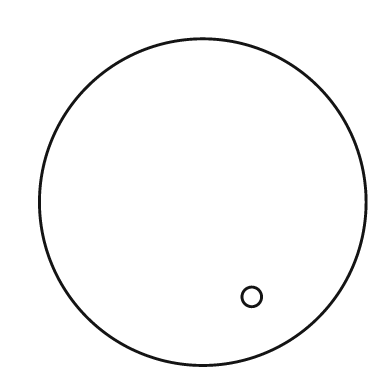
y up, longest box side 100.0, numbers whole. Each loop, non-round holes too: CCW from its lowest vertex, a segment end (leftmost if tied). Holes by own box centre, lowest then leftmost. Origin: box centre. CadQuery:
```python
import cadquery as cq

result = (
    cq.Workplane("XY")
    .moveTo(0.0, 0.0)
    .circle(50.0)
    .moveTo(15.0, -29.0)
    .circle(3.0)
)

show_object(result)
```